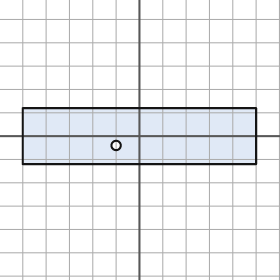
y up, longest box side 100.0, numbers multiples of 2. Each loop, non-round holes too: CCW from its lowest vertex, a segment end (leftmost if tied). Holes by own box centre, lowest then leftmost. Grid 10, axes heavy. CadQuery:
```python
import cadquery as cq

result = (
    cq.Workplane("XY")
    .moveTo(-50.0, -12.0)
    .lineTo(50.0, -12.0)
    .lineTo(50.0, 12.0)
    .lineTo(-50.0, 12.0)
    .close()
    .moveTo(-10.0, -4.0)
    .circle(2.0)
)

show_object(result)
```